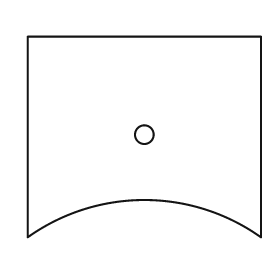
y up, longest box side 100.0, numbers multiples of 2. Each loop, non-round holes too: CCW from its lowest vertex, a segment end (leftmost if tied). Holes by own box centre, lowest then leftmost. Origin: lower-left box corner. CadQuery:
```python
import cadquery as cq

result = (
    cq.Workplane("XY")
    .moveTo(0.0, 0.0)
    .threePointArc((50.0, 16.0), (100.0, 0.0))
    .lineTo(100.0, 86.0)
    .lineTo(0.0, 86.0)
    .close()
    .moveTo(50.0, 44.0)
    .circle(4.0)
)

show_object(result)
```